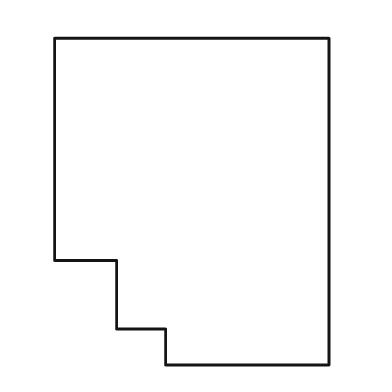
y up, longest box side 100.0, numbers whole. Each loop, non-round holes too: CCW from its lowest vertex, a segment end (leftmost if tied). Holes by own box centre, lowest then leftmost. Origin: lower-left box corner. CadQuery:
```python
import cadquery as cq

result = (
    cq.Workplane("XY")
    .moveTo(34.0, 0.0)
    .lineTo(84.0, 0.0)
    .lineTo(84.0, 100.0)
    .lineTo(0.0, 100.0)
    .lineTo(0.0, 32.0)
    .lineTo(19.0, 32.0)
    .lineTo(19.0, 11.0)
    .lineTo(34.0, 11.0)
    .close()
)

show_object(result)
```